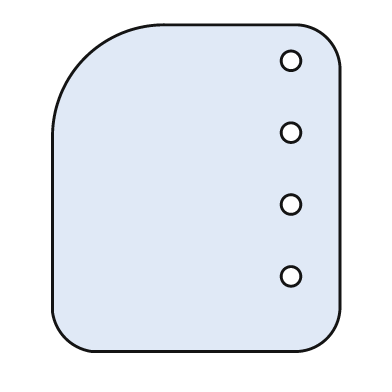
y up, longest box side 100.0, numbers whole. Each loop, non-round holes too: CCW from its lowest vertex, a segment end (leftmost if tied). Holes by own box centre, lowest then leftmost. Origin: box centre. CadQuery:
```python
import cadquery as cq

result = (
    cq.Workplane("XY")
    .moveTo(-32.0, -50.0)
    .lineTo(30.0, -50.0)
    .threePointArc((40.0, -46.0), (44.0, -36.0))
    .lineTo(44.0, 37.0)
    .threePointArc((40.0, 46.0), (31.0, 50.0))
    .lineTo(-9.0, 50.0)
    .threePointArc((-34.0, 40.0), (-44.0, 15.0))
    .lineTo(-44.0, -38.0)
    .threePointArc((-40.0, -46.0), (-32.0, -50.0))
    .close()
    .moveTo(29.0, -27.0)
    .circle(3.0)
    .moveTo(29.0, -5.0)
    .circle(3.0)
    .moveTo(29.0, 17.0)
    .circle(3.0)
    .moveTo(29.0, 39.0)
    .circle(3.0)
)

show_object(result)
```